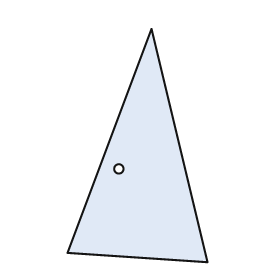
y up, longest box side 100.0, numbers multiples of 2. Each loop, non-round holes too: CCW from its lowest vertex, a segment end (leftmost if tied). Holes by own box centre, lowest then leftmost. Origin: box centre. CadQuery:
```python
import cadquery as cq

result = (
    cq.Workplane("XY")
    .moveTo(30.0, -50.0)
    .lineTo(6.0, 50.0)
    .lineTo(-30.0, -46.0)
    .close()
    .moveTo(-8.0, -10.0)
    .circle(2.0)
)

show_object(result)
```